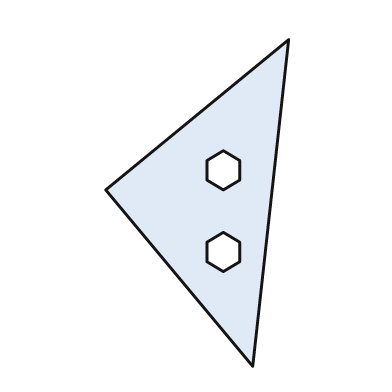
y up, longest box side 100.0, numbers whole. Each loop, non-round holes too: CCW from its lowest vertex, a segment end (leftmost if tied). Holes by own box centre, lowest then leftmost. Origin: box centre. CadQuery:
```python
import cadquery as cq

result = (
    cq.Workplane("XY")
    .moveTo(17.0, -50.0)
    .lineTo(28.0, 50.0)
    .lineTo(-28.0, 4.0)
    .close()
    .moveTo(8.0, -21.0)
    .lineTo(13.0, -18.0)
    .lineTo(13.0, -12.0)
    .lineTo(8.0, -9.0)
    .lineTo(3.0, -12.0)
    .lineTo(3.0, -18.0)
    .close()
    .moveTo(8.0, 4.0)
    .lineTo(13.0, 7.0)
    .lineTo(13.0, 13.0)
    .lineTo(8.0, 16.0)
    .lineTo(3.0, 13.0)
    .lineTo(3.0, 7.0)
    .close()
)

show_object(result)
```